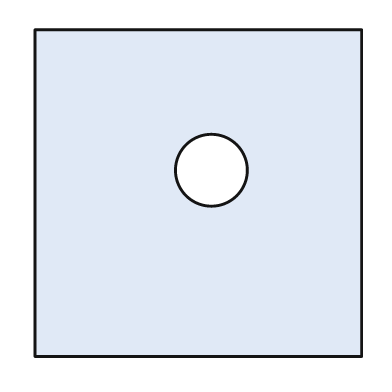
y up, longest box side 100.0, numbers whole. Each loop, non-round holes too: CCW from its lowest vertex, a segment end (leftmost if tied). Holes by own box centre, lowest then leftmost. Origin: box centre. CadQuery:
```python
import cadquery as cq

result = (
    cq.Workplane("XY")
    .moveTo(-50.0, -50.0)
    .lineTo(50.0, -50.0)
    .lineTo(50.0, 50.0)
    .lineTo(-50.0, 50.0)
    .close()
    .moveTo(4.0, 7.0)
    .circle(11.0)
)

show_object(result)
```